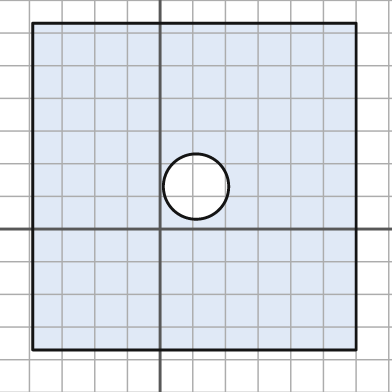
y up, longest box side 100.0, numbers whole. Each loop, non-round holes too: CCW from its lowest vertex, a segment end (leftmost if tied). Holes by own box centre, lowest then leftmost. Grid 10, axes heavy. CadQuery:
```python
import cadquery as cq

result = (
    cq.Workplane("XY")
    .moveTo(-39.0, -37.0)
    .lineTo(60.0, -37.0)
    .lineTo(60.0, 63.0)
    .lineTo(-39.0, 63.0)
    .close()
    .moveTo(11.0, 13.0)
    .circle(10.0)
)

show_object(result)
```